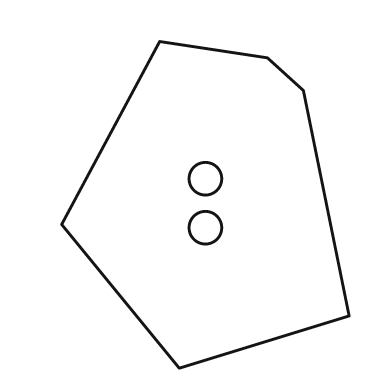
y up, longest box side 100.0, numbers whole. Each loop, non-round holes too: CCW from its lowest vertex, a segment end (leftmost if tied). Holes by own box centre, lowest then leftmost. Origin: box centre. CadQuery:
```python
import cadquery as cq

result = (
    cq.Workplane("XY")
    .moveTo(-8.0, -50.0)
    .lineTo(44.0, -34.0)
    .lineTo(30.0, 35.0)
    .lineTo(19.0, 45.0)
    .lineTo(-14.0, 50.0)
    .lineTo(-44.0, -6.0)
    .close()
    .moveTo(0.0, -7.0)
    .circle(5.0)
    .moveTo(0.0, 8.0)
    .circle(5.0)
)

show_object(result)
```